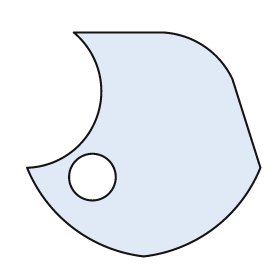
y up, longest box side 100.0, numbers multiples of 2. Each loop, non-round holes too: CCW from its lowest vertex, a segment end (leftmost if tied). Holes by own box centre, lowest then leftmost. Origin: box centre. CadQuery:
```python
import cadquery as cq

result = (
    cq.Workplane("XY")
    .moveTo(0.0, -48.0)
    .threePointArc((30.0, -36.0), (50.0, -10.0))
    .lineTo(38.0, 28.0)
    .threePointArc((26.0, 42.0), (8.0, 48.0))
    .lineTo(-30.0, 48.0)
    .threePointArc((-20.0, 12.0), (-50.0, -10.0))
    .threePointArc((-30.0, -36.0), (0.0, -48.0))
    .close()
    .moveTo(-22.0, -14.0)
    .circle(10.0)
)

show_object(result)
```